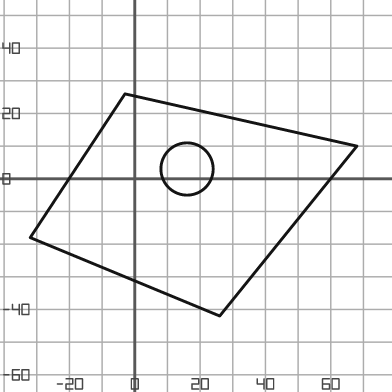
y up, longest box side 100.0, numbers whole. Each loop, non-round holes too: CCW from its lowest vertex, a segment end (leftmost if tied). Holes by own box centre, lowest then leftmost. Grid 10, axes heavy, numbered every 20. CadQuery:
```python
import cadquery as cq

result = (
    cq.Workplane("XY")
    .moveTo(26.0, -42.0)
    .lineTo(68.0, 10.0)
    .lineTo(-3.0, 26.0)
    .lineTo(-32.0, -18.0)
    .close()
    .moveTo(16.0, 3.0)
    .circle(8.0)
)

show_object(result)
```